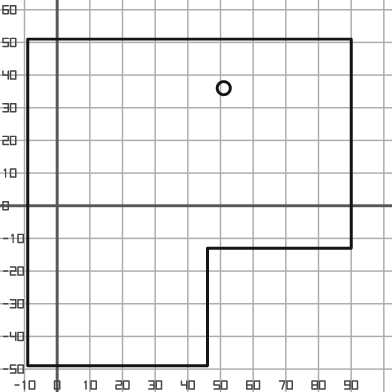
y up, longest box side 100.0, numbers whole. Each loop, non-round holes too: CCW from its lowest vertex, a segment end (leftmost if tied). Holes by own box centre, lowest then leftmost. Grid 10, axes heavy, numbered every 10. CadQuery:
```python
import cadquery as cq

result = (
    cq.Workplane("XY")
    .moveTo(-9.0, -49.0)
    .lineTo(46.0, -49.0)
    .lineTo(46.0, -13.0)
    .lineTo(90.0, -13.0)
    .lineTo(90.0, 51.0)
    .lineTo(-9.0, 51.0)
    .close()
    .moveTo(51.0, 36.0)
    .circle(2.0)
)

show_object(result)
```